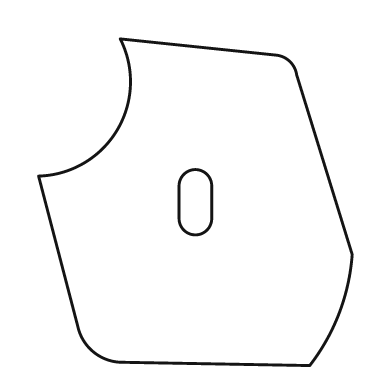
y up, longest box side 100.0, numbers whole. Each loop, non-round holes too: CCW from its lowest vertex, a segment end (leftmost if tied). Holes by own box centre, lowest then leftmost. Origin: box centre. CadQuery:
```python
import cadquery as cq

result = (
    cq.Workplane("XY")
    .moveTo(35.0, -50.0)
    .threePointArc((44.0, -34.0), (48.0, -16.0))
    .lineTo(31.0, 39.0)
    .threePointArc((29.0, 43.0), (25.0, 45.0))
    .lineTo(-23.0, 50.0)
    .threePointArc((-24.0, 22.0), (-48.0, 8.0))
    .lineTo(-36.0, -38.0)
    .threePointArc((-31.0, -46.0), (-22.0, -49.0))
    .close()
    .moveTo(-5.0, -5.0)
    .threePointArc((0.0, -10.0), (5.0, -5.0))
    .lineTo(5.0, 5.0)
    .threePointArc((0.0, 10.0), (-5.0, 5.0))
    .close()
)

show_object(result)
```